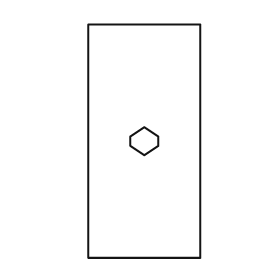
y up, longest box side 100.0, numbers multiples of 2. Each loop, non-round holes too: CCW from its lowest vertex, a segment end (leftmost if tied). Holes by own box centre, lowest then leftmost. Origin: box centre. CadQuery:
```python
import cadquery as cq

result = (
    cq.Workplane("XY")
    .moveTo(-24.0, -50.0)
    .lineTo(24.0, -50.0)
    .lineTo(24.0, 50.0)
    .lineTo(-24.0, 50.0)
    .close()
    .moveTo(0.0, -6.0)
    .lineTo(6.0, -2.0)
    .lineTo(6.0, 2.0)
    .lineTo(0.0, 6.0)
    .lineTo(-6.0, 2.0)
    .lineTo(-6.0, -2.0)
    .close()
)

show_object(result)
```